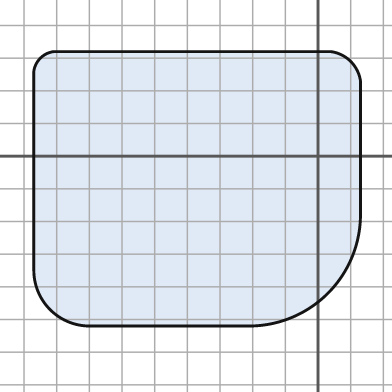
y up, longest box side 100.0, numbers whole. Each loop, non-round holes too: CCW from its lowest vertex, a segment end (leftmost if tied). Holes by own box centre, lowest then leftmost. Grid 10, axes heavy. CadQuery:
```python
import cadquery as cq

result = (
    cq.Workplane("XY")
    .moveTo(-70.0, -52.0)
    .lineTo(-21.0, -52.0)
    .threePointArc((3.0, -42.0), (13.0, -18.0))
    .lineTo(13.0, 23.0)
    .threePointArc((10.0, 29.0), (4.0, 32.0))
    .lineTo(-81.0, 32.0)
    .threePointArc((-85.0, 30.0), (-87.0, 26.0))
    .lineTo(-87.0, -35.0)
    .threePointArc((-82.0, -47.0), (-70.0, -52.0))
    .close()
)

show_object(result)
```